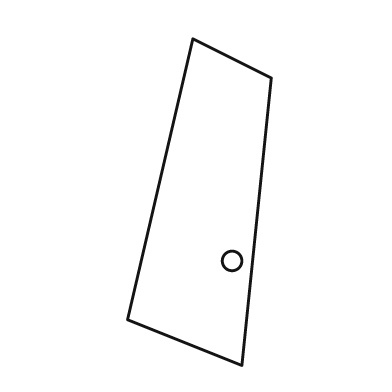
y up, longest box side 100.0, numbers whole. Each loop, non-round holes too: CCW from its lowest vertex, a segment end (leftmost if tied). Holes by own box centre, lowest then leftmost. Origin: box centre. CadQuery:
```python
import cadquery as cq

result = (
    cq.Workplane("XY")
    .moveTo(13.0, -50.0)
    .lineTo(22.0, 38.0)
    .lineTo(-2.0, 50.0)
    .lineTo(-22.0, -36.0)
    .close()
    .moveTo(10.0, -18.0)
    .circle(3.0)
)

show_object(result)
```